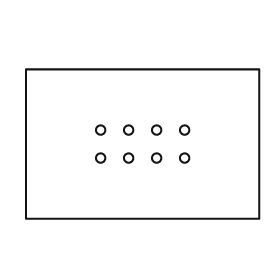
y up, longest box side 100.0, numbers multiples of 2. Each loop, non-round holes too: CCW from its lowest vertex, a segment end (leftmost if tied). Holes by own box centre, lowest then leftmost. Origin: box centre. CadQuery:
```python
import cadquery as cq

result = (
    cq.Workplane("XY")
    .moveTo(-50.0, -32.0)
    .lineTo(50.0, -32.0)
    .lineTo(50.0, 32.0)
    .lineTo(-50.0, 32.0)
    .close()
    .moveTo(-18.0, -6.0)
    .circle(2.0)
    .moveTo(-6.0, -6.0)
    .circle(2.0)
    .moveTo(6.0, -6.0)
    .circle(2.0)
    .moveTo(18.0, -6.0)
    .circle(2.0)
    .moveTo(-18.0, 6.0)
    .circle(2.0)
    .moveTo(-6.0, 6.0)
    .circle(2.0)
    .moveTo(6.0, 6.0)
    .circle(2.0)
    .moveTo(18.0, 6.0)
    .circle(2.0)
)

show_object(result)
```